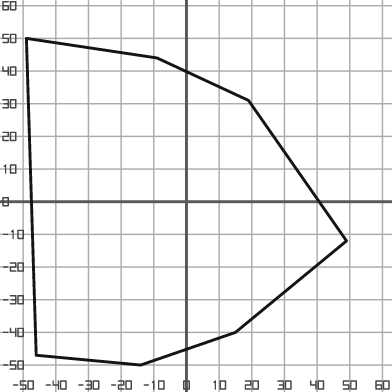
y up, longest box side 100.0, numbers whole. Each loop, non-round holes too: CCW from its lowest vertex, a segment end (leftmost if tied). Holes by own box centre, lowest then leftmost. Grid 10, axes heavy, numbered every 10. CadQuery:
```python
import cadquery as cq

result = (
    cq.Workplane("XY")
    .moveTo(-14.0, -50.0)
    .lineTo(15.0, -40.0)
    .lineTo(49.0, -12.0)
    .lineTo(19.0, 31.0)
    .lineTo(-9.0, 44.0)
    .lineTo(-49.0, 50.0)
    .lineTo(-46.0, -47.0)
    .close()
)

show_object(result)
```